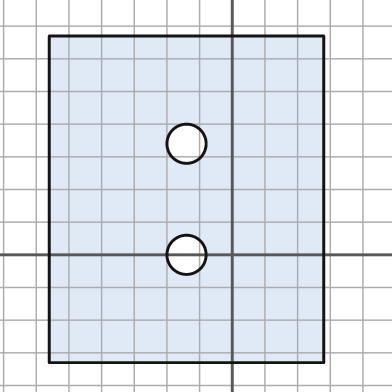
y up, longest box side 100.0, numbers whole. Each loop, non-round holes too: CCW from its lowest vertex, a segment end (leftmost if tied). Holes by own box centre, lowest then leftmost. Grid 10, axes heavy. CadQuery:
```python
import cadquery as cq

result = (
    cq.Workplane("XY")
    .moveTo(-56.0, -33.0)
    .lineTo(28.0, -33.0)
    .lineTo(28.0, 67.0)
    .lineTo(-56.0, 67.0)
    .close()
    .moveTo(-14.0, 0.0)
    .circle(6.0)
    .moveTo(-14.0, 34.0)
    .circle(6.0)
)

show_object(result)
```